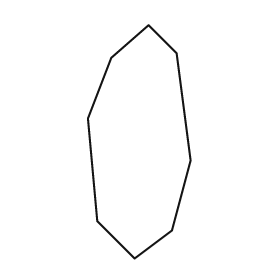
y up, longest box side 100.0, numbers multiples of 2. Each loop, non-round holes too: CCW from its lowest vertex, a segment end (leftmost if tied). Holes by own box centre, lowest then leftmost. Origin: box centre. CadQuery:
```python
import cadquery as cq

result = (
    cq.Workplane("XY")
    .moveTo(-2.0, -50.0)
    .lineTo(14.0, -38.0)
    .lineTo(22.0, -8.0)
    .lineTo(16.0, 38.0)
    .lineTo(4.0, 50.0)
    .lineTo(-12.0, 36.0)
    .lineTo(-22.0, 10.0)
    .lineTo(-18.0, -34.0)
    .close()
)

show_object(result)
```